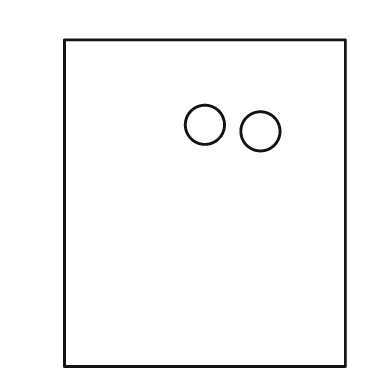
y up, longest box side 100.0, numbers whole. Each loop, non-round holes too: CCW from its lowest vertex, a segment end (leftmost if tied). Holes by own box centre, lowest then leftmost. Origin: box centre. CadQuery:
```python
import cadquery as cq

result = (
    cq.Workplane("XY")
    .moveTo(-43.0, -50.0)
    .lineTo(43.0, -50.0)
    .lineTo(43.0, 50.0)
    .lineTo(-43.0, 50.0)
    .close()
    .moveTo(17.0, 22.0)
    .circle(6.0)
    .moveTo(0.0, 24.0)
    .circle(6.0)
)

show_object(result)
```